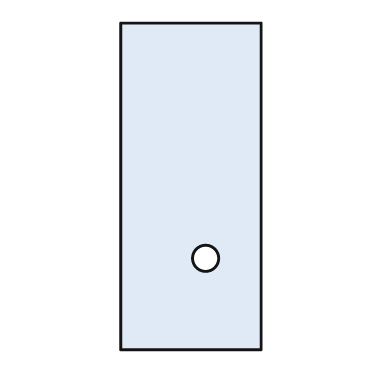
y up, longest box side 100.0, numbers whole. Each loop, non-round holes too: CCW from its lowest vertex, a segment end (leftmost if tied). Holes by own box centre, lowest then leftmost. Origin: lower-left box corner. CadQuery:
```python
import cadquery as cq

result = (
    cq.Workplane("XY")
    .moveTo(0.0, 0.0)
    .lineTo(43.0, 0.0)
    .lineTo(43.0, 100.0)
    .lineTo(0.0, 100.0)
    .close()
    .moveTo(26.0, 28.0)
    .circle(4.0)
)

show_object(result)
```